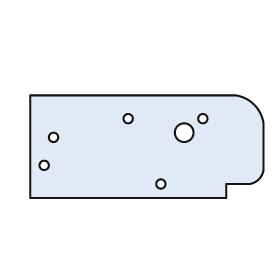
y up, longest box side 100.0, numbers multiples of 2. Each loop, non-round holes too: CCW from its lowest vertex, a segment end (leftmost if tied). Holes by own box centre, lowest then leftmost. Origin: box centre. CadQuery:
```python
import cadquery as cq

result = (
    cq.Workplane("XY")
    .moveTo(-50.0, -22.0)
    .lineTo(34.0, -22.0)
    .lineTo(34.0, -16.0)
    .lineTo(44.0, -16.0)
    .threePointArc((48.0, -14.0), (50.0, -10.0))
    .lineTo(50.0, 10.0)
    .threePointArc((46.0, 18.0), (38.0, 22.0))
    .lineTo(-50.0, 22.0)
    .close()
    .moveTo(6.0, -16.0)
    .circle(2.0)
    .moveTo(-44.0, -8.0)
    .circle(2.0)
    .moveTo(-40.0, 4.0)
    .circle(2.0)
    .moveTo(16.0, 6.0)
    .circle(4.0)
    .moveTo(-8.0, 12.0)
    .circle(2.0)
    .moveTo(24.0, 12.0)
    .circle(2.0)
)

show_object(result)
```